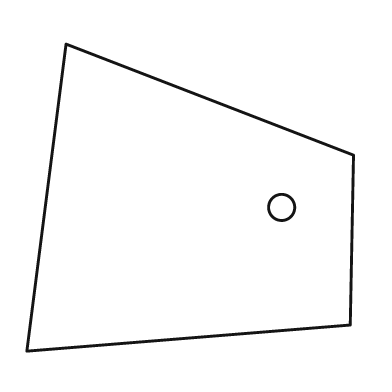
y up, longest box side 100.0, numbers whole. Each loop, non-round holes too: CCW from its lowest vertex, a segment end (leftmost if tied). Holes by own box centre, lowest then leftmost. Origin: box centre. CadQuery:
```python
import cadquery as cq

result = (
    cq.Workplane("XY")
    .moveTo(-50.0, -47.0)
    .lineTo(49.0, -39.0)
    .lineTo(50.0, 13.0)
    .lineTo(-38.0, 47.0)
    .close()
    .moveTo(28.0, -3.0)
    .circle(4.0)
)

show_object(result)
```